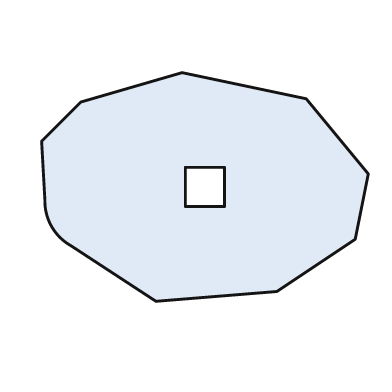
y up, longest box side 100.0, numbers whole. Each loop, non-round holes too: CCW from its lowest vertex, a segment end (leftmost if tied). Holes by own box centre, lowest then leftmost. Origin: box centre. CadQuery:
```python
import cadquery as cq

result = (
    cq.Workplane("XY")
    .moveTo(-15.0, -35.0)
    .lineTo(22.0, -32.0)
    .lineTo(46.0, -16.0)
    .lineTo(50.0, 4.0)
    .lineTo(31.0, 27.0)
    .lineTo(-7.0, 35.0)
    .lineTo(-38.0, 26.0)
    .lineTo(-50.0, 14.0)
    .lineTo(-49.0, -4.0)
    .threePointArc((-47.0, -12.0), (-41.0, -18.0))
    .close()
    .moveTo(-6.0, -6.0)
    .lineTo(6.0, -6.0)
    .lineTo(6.0, 6.0)
    .lineTo(-6.0, 6.0)
    .close()
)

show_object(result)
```